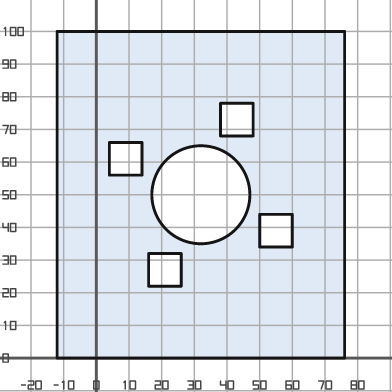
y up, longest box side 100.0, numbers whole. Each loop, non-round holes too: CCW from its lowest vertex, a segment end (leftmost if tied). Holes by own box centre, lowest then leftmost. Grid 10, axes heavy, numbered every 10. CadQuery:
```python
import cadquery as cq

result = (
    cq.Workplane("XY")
    .moveTo(-12.0, 0.0)
    .lineTo(76.0, 0.0)
    .lineTo(76.0, 100.0)
    .lineTo(-12.0, 100.0)
    .close()
    .moveTo(16.0, 22.0)
    .lineTo(26.0, 22.0)
    .lineTo(26.0, 32.0)
    .lineTo(16.0, 32.0)
    .close()
    .moveTo(50.0, 34.0)
    .lineTo(60.0, 34.0)
    .lineTo(60.0, 44.0)
    .lineTo(50.0, 44.0)
    .close()
    .moveTo(32.0, 50.0)
    .circle(15.0)
    .moveTo(4.0, 56.0)
    .lineTo(14.0, 56.0)
    .lineTo(14.0, 66.0)
    .lineTo(4.0, 66.0)
    .close()
    .moveTo(38.0, 68.0)
    .lineTo(48.0, 68.0)
    .lineTo(48.0, 78.0)
    .lineTo(38.0, 78.0)
    .close()
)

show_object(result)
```